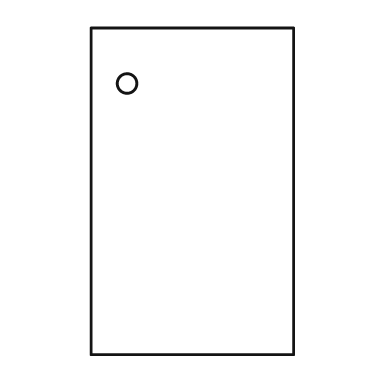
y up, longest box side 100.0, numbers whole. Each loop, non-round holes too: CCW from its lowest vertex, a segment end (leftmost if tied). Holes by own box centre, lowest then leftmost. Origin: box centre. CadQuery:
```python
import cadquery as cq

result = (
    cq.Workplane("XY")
    .moveTo(-31.0, -50.0)
    .lineTo(31.0, -50.0)
    .lineTo(31.0, 50.0)
    .lineTo(-31.0, 50.0)
    .close()
    .moveTo(-20.0, 33.0)
    .circle(3.0)
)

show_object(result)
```